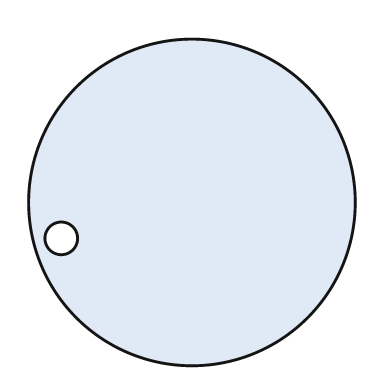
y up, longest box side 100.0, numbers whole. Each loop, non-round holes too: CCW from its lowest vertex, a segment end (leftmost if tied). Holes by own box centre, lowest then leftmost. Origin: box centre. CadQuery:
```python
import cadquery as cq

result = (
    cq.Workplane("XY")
    .moveTo(0.0, 0.0)
    .circle(50.0)
    .moveTo(-40.0, -11.0)
    .circle(5.0)
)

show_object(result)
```